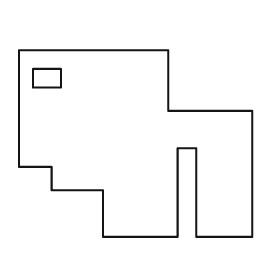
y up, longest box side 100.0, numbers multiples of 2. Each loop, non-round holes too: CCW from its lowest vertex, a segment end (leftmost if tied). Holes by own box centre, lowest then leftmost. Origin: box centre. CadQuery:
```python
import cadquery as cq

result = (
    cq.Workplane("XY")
    .moveTo(-14.0, -40.0)
    .lineTo(18.0, -40.0)
    .lineTo(18.0, -2.0)
    .lineTo(26.0, -2.0)
    .lineTo(26.0, -40.0)
    .lineTo(50.0, -40.0)
    .lineTo(50.0, 14.0)
    .lineTo(14.0, 14.0)
    .lineTo(14.0, 40.0)
    .lineTo(-50.0, 40.0)
    .lineTo(-50.0, -10.0)
    .lineTo(-36.0, -10.0)
    .lineTo(-36.0, -20.0)
    .lineTo(-14.0, -20.0)
    .close()
    .moveTo(-44.0, 24.0)
    .lineTo(-32.0, 24.0)
    .lineTo(-32.0, 32.0)
    .lineTo(-44.0, 32.0)
    .close()
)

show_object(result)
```